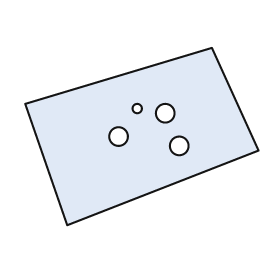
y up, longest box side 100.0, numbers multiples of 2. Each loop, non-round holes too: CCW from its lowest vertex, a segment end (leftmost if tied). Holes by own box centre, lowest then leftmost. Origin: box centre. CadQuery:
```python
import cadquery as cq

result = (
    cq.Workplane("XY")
    .moveTo(-32.0, -38.0)
    .lineTo(50.0, -6.0)
    .lineTo(30.0, 38.0)
    .lineTo(-50.0, 14.0)
    .close()
    .moveTo(16.0, -4.0)
    .circle(4.0)
    .moveTo(-10.0, 0.0)
    .circle(4.0)
    .moveTo(10.0, 10.0)
    .circle(4.0)
    .moveTo(-2.0, 12.0)
    .circle(2.0)
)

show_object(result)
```